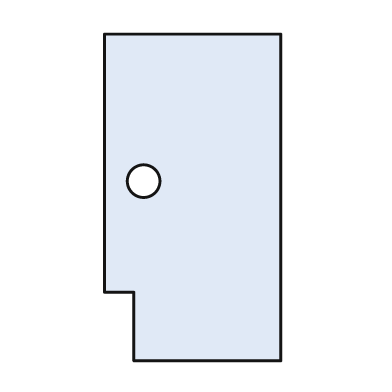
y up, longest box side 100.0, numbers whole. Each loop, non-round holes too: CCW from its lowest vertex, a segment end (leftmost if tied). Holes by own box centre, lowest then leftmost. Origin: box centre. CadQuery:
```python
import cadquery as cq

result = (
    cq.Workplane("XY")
    .moveTo(-18.0, -50.0)
    .lineTo(27.0, -50.0)
    .lineTo(27.0, 50.0)
    .lineTo(-27.0, 50.0)
    .lineTo(-27.0, -29.0)
    .lineTo(-18.0, -29.0)
    .close()
    .moveTo(-15.0, 5.0)
    .circle(5.0)
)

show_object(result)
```